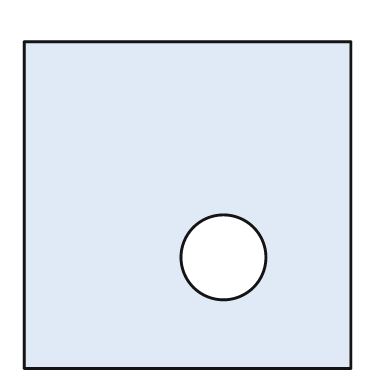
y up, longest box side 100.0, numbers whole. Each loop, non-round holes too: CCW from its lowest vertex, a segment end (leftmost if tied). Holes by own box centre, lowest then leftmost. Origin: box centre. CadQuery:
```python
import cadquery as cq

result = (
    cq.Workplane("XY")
    .moveTo(-50.0, -50.0)
    .lineTo(50.0, -50.0)
    .lineTo(50.0, 50.0)
    .lineTo(-50.0, 50.0)
    .close()
    .moveTo(11.0, -16.0)
    .circle(13.0)
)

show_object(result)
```